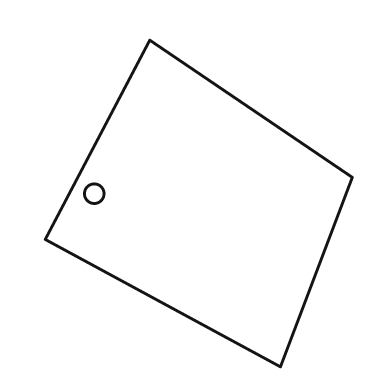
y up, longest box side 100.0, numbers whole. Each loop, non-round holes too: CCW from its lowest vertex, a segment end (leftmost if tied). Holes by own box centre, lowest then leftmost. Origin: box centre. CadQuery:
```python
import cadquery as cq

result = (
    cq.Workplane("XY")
    .moveTo(25.0, -50.0)
    .lineTo(47.0, 8.0)
    .lineTo(-15.0, 50.0)
    .lineTo(-47.0, -11.0)
    .close()
    .moveTo(-32.0, 3.0)
    .circle(3.0)
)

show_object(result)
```